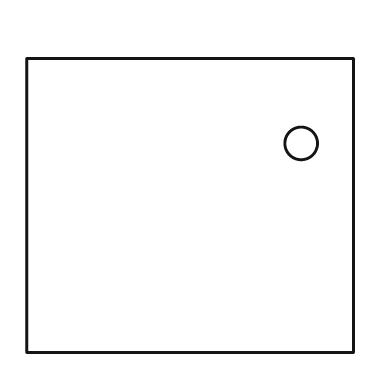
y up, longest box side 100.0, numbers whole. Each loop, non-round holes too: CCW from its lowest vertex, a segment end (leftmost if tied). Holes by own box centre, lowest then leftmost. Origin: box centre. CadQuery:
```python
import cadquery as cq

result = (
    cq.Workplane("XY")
    .moveTo(-50.0, -45.0)
    .lineTo(50.0, -45.0)
    .lineTo(50.0, 45.0)
    .lineTo(-50.0, 45.0)
    .close()
    .moveTo(34.0, 19.0)
    .circle(5.0)
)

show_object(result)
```